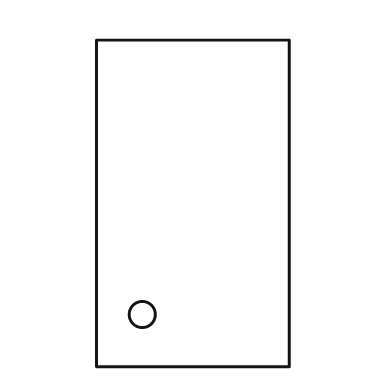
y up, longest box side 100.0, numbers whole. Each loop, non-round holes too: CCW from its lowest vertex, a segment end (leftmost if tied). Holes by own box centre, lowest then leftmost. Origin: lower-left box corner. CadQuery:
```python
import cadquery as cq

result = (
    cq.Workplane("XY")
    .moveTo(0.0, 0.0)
    .lineTo(59.0, 0.0)
    .lineTo(59.0, 100.0)
    .lineTo(0.0, 100.0)
    .close()
    .moveTo(14.0, 16.0)
    .circle(4.0)
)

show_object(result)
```